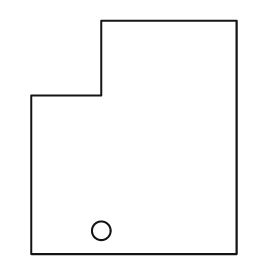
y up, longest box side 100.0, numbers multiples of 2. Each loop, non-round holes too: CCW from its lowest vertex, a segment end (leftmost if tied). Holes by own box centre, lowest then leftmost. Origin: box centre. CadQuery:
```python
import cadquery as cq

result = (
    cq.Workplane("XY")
    .moveTo(-44.0, -50.0)
    .lineTo(44.0, -50.0)
    .lineTo(44.0, 50.0)
    .lineTo(-14.0, 50.0)
    .lineTo(-14.0, 18.0)
    .lineTo(-44.0, 18.0)
    .close()
    .moveTo(-14.0, -40.0)
    .circle(4.0)
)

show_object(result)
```